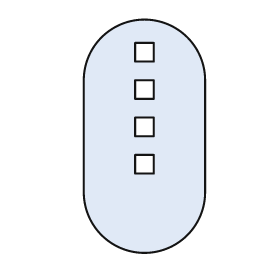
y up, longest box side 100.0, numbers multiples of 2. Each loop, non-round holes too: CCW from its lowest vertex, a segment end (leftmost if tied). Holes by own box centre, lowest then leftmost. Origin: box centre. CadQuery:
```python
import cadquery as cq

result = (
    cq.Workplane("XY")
    .moveTo(-26.0, -24.0)
    .threePointArc((0.0, -50.0), (26.0, -24.0))
    .lineTo(26.0, 24.0)
    .threePointArc((0.0, 50.0), (-26.0, 24.0))
    .close()
    .moveTo(-4.0, -16.0)
    .lineTo(4.0, -16.0)
    .lineTo(4.0, -8.0)
    .lineTo(-4.0, -8.0)
    .close()
    .moveTo(-4.0, 0.0)
    .lineTo(4.0, 0.0)
    .lineTo(4.0, 8.0)
    .lineTo(-4.0, 8.0)
    .close()
    .moveTo(-4.0, 16.0)
    .lineTo(4.0, 16.0)
    .lineTo(4.0, 24.0)
    .lineTo(-4.0, 24.0)
    .close()
    .moveTo(-4.0, 32.0)
    .lineTo(4.0, 32.0)
    .lineTo(4.0, 40.0)
    .lineTo(-4.0, 40.0)
    .close()
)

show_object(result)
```